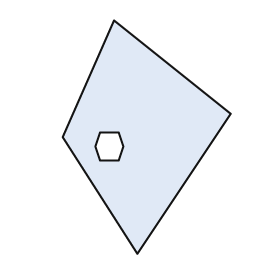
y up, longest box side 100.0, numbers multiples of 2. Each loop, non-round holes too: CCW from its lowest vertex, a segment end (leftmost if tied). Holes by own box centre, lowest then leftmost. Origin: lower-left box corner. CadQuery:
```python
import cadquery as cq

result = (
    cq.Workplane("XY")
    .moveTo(32.0, 0.0)
    .lineTo(72.0, 60.0)
    .lineTo(22.0, 100.0)
    .lineTo(0.0, 50.0)
    .close()
    .moveTo(16.0, 40.0)
    .lineTo(24.0, 40.0)
    .lineTo(26.0, 46.0)
    .lineTo(24.0, 52.0)
    .lineTo(16.0, 52.0)
    .lineTo(14.0, 46.0)
    .close()
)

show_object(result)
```